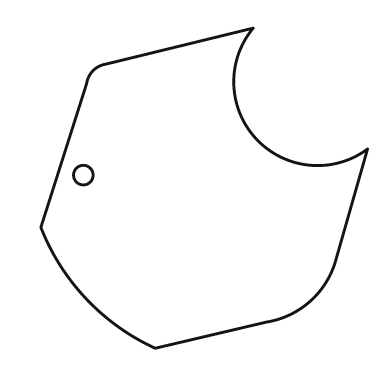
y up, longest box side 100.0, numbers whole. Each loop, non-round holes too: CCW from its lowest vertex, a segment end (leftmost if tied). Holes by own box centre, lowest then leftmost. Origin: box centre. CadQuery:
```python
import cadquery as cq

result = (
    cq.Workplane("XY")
    .moveTo(-15.0, -49.0)
    .lineTo(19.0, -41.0)
    .threePointArc((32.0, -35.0), (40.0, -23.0))
    .lineTo(50.0, 12.0)
    .threePointArc((16.0, 15.0), (15.0, 49.0))
    .lineTo(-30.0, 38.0)
    .threePointArc((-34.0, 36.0), (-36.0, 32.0))
    .lineTo(-50.0, -12.0)
    .threePointArc((-36.0, -34.0), (-15.0, -49.0))
    .close()
    .moveTo(-37.0, 4.0)
    .circle(3.0)
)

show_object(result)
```